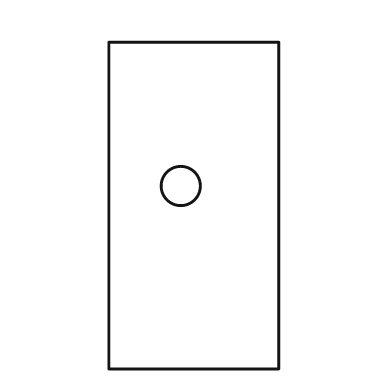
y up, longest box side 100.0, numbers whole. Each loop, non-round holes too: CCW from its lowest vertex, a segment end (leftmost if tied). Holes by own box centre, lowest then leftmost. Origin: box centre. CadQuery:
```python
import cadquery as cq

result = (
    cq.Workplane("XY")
    .moveTo(-26.0, -50.0)
    .lineTo(26.0, -50.0)
    .lineTo(26.0, 50.0)
    .lineTo(-26.0, 50.0)
    .close()
    .moveTo(-4.0, 6.0)
    .circle(6.0)
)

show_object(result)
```